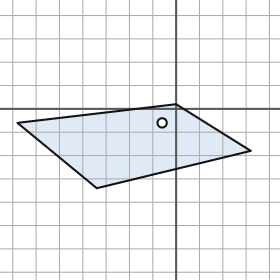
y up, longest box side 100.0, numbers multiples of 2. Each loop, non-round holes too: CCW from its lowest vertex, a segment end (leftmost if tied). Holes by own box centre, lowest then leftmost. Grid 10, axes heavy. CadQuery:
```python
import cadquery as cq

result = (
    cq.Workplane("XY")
    .moveTo(-34.0, -34.0)
    .lineTo(32.0, -18.0)
    .lineTo(0.0, 2.0)
    .lineTo(-68.0, -6.0)
    .close()
    .moveTo(-6.0, -6.0)
    .circle(2.0)
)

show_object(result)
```